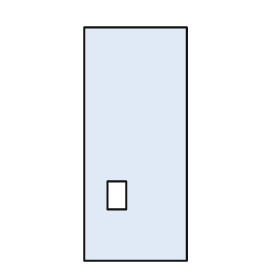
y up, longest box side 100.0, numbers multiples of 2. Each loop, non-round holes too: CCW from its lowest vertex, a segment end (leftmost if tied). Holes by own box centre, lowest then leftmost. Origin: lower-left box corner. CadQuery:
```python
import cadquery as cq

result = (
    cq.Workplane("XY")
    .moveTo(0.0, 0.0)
    .lineTo(44.0, 0.0)
    .lineTo(44.0, 100.0)
    .lineTo(0.0, 100.0)
    .close()
    .moveTo(10.0, 22.0)
    .lineTo(18.0, 22.0)
    .lineTo(18.0, 34.0)
    .lineTo(10.0, 34.0)
    .close()
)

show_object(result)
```